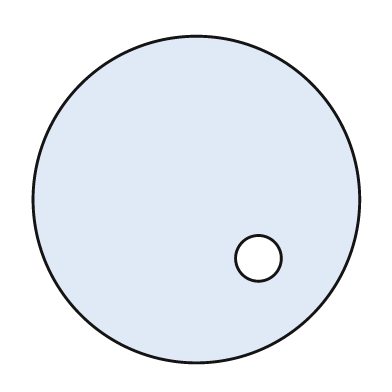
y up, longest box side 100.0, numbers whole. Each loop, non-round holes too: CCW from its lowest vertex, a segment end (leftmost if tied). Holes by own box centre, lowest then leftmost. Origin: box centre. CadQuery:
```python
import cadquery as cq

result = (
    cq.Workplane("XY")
    .moveTo(0.0, 0.0)
    .circle(50.0)
    .moveTo(19.0, -18.0)
    .circle(7.0)
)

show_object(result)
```